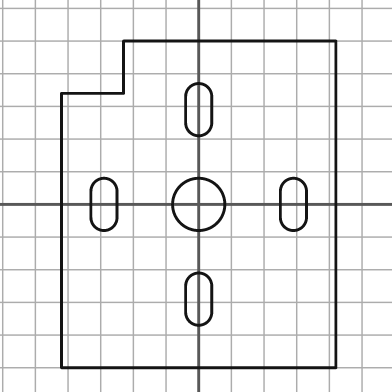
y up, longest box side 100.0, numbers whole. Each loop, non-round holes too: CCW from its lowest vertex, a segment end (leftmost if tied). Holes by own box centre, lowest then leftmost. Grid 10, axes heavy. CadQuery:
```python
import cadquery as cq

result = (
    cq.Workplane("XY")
    .moveTo(-42.0, -50.0)
    .lineTo(42.0, -50.0)
    .lineTo(42.0, 50.0)
    .lineTo(-23.0, 50.0)
    .lineTo(-23.0, 34.0)
    .lineTo(-42.0, 34.0)
    .close()
    .moveTo(-4.0, -33.0)
    .threePointArc((0.0, -37.0), (4.0, -33.0))
    .lineTo(4.0, -25.0)
    .threePointArc((0.0, -21.0), (-4.0, -25.0))
    .close()
    .moveTo(-33.0, -4.0)
    .threePointArc((-29.0, -8.0), (-25.0, -4.0))
    .lineTo(-25.0, 4.0)
    .threePointArc((-29.0, 8.0), (-33.0, 4.0))
    .close()
    .moveTo(0.0, 0.0)
    .circle(8.0)
    .moveTo(25.0, -4.0)
    .threePointArc((29.0, -8.0), (33.0, -4.0))
    .lineTo(33.0, 4.0)
    .threePointArc((29.0, 8.0), (25.0, 4.0))
    .close()
    .moveTo(-4.0, 25.0)
    .threePointArc((0.0, 21.0), (4.0, 25.0))
    .lineTo(4.0, 33.0)
    .threePointArc((0.0, 37.0), (-4.0, 33.0))
    .close()
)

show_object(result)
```